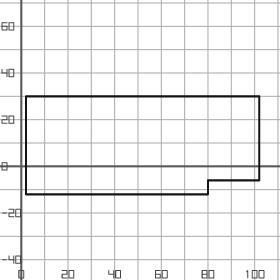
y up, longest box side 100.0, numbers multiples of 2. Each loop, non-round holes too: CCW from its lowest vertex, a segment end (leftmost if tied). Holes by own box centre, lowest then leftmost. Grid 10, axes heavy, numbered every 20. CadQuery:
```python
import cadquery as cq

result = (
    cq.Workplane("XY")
    .moveTo(2.0, -12.0)
    .lineTo(80.0, -12.0)
    .lineTo(80.0, -6.0)
    .lineTo(102.0, -6.0)
    .lineTo(102.0, 30.0)
    .lineTo(2.0, 30.0)
    .close()
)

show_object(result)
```